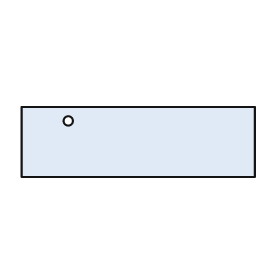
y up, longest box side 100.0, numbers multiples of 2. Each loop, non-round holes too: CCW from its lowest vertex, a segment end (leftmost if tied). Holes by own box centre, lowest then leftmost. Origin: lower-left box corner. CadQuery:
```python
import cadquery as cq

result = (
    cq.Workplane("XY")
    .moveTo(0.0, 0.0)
    .lineTo(100.0, 0.0)
    .lineTo(100.0, 30.0)
    .lineTo(0.0, 30.0)
    .close()
    .moveTo(20.0, 24.0)
    .circle(2.0)
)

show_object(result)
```